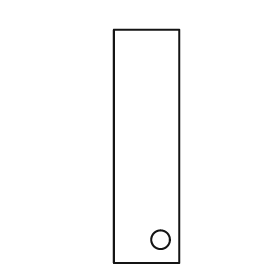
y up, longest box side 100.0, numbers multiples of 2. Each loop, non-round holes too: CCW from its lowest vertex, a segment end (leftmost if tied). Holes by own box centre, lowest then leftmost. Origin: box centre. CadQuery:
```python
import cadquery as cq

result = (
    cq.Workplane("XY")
    .moveTo(-14.0, -50.0)
    .lineTo(14.0, -50.0)
    .lineTo(14.0, 50.0)
    .lineTo(-14.0, 50.0)
    .close()
    .moveTo(6.0, -40.0)
    .circle(4.0)
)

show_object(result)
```